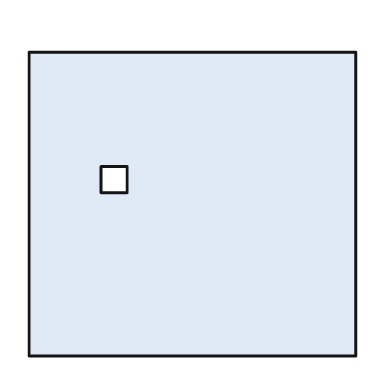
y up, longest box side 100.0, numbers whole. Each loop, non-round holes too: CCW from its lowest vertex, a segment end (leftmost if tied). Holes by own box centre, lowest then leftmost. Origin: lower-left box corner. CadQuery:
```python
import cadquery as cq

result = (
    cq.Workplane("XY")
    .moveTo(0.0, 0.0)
    .lineTo(100.0, 0.0)
    .lineTo(100.0, 93.0)
    .lineTo(0.0, 93.0)
    .close()
    .moveTo(22.0, 50.0)
    .lineTo(30.0, 50.0)
    .lineTo(30.0, 58.0)
    .lineTo(22.0, 58.0)
    .close()
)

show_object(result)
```